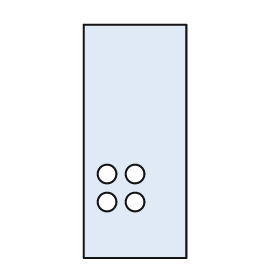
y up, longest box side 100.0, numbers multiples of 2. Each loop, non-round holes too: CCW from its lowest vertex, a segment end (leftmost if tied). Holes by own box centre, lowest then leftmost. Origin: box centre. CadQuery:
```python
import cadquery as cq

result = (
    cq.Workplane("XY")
    .moveTo(-22.0, -50.0)
    .lineTo(22.0, -50.0)
    .lineTo(22.0, 50.0)
    .lineTo(-22.0, 50.0)
    .close()
    .moveTo(-12.0, -26.0)
    .circle(4.0)
    .moveTo(0.0, -26.0)
    .circle(4.0)
    .moveTo(-12.0, -14.0)
    .circle(4.0)
    .moveTo(0.0, -14.0)
    .circle(4.0)
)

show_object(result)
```